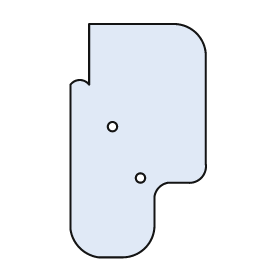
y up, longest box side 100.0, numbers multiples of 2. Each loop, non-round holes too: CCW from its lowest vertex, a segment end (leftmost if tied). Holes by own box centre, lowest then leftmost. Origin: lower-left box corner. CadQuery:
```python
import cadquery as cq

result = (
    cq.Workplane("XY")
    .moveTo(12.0, 0.0)
    .lineTo(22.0, 0.0)
    .threePointArc((32.0, 4.0), (36.0, 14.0))
    .lineTo(36.0, 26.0)
    .threePointArc((38.0, 30.0), (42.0, 32.0))
    .lineTo(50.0, 32.0)
    .threePointArc((56.0, 34.0), (58.0, 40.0))
    .lineTo(58.0, 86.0)
    .threePointArc((54.0, 96.0), (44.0, 100.0))
    .lineTo(8.0, 100.0)
    .lineTo(8.0, 74.0)
    .threePointArc((4.0, 76.0), (0.0, 74.0))
    .lineTo(0.0, 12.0)
    .threePointArc((4.0, 4.0), (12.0, 0.0))
    .close()
    .moveTo(30.0, 34.0)
    .circle(2.0)
    .moveTo(18.0, 56.0)
    .circle(2.0)
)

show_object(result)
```